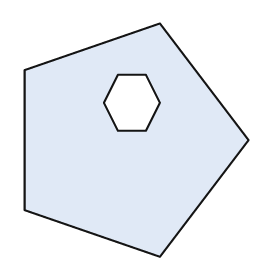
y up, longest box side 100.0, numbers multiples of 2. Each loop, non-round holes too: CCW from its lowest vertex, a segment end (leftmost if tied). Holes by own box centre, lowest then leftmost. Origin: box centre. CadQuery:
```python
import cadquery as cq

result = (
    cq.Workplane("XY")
    .moveTo(10.0, -50.0)
    .lineTo(48.0, 0.0)
    .lineTo(10.0, 50.0)
    .lineTo(-48.0, 30.0)
    .lineTo(-48.0, -30.0)
    .close()
    .moveTo(-8.0, 4.0)
    .lineTo(4.0, 4.0)
    .lineTo(10.0, 16.0)
    .lineTo(4.0, 28.0)
    .lineTo(-8.0, 28.0)
    .lineTo(-14.0, 16.0)
    .close()
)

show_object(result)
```